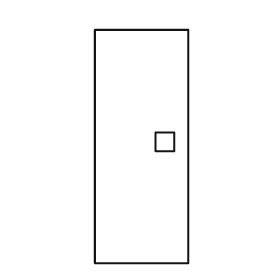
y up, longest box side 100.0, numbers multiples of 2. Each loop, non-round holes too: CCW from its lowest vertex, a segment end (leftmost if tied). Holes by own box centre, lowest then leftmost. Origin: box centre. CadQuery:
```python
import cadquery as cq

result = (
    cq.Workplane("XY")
    .moveTo(-20.0, -50.0)
    .lineTo(20.0, -50.0)
    .lineTo(20.0, 50.0)
    .lineTo(-20.0, 50.0)
    .close()
    .moveTo(6.0, -2.0)
    .lineTo(14.0, -2.0)
    .lineTo(14.0, 6.0)
    .lineTo(6.0, 6.0)
    .close()
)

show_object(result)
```